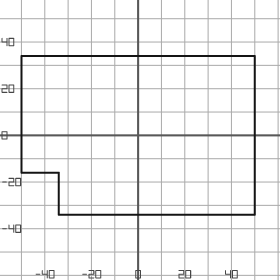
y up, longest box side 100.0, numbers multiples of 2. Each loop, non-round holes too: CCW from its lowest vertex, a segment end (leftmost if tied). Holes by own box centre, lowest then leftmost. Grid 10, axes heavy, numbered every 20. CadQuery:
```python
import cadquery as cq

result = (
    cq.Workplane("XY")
    .moveTo(-34.0, -34.0)
    .lineTo(50.0, -34.0)
    .lineTo(50.0, 34.0)
    .lineTo(-50.0, 34.0)
    .lineTo(-50.0, -16.0)
    .lineTo(-34.0, -16.0)
    .close()
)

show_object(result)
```